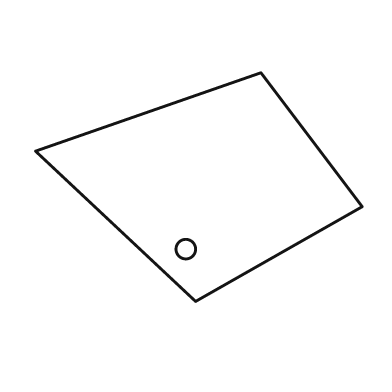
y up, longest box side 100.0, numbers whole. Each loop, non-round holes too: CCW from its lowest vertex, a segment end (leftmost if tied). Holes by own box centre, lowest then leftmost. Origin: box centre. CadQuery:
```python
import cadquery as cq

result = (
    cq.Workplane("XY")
    .moveTo(-1.0, -35.0)
    .lineTo(50.0, -6.0)
    .lineTo(19.0, 35.0)
    .lineTo(-50.0, 11.0)
    .close()
    .moveTo(-4.0, -19.0)
    .circle(3.0)
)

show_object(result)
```